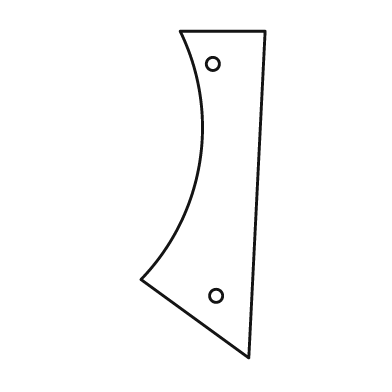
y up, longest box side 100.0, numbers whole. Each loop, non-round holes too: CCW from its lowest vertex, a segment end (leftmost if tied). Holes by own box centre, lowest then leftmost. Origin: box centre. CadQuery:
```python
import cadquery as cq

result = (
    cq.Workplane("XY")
    .moveTo(14.0, -50.0)
    .lineTo(19.0, 50.0)
    .lineTo(-7.0, 50.0)
    .threePointArc((-1.0, 10.0), (-19.0, -26.0))
    .close()
    .moveTo(4.0, -31.0)
    .circle(2.0)
    .moveTo(3.0, 40.0)
    .circle(2.0)
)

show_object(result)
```